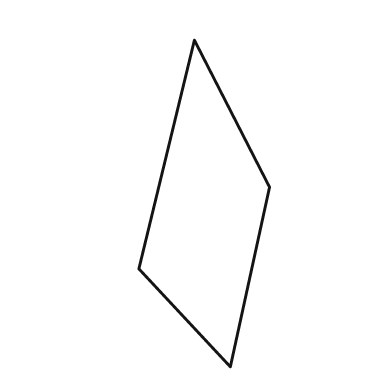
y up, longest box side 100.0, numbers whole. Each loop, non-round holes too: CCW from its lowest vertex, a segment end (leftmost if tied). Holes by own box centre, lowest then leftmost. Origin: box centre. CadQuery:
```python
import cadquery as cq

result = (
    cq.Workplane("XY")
    .moveTo(8.0, -50.0)
    .lineTo(20.0, 5.0)
    .lineTo(-3.0, 50.0)
    .lineTo(-20.0, -20.0)
    .close()
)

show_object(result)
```